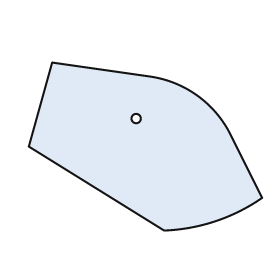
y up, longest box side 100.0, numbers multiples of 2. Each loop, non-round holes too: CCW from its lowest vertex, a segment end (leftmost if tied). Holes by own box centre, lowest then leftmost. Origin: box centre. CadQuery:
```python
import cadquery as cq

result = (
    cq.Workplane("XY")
    .moveTo(8.0, -36.0)
    .threePointArc((30.0, -32.0), (50.0, -22.0))
    .lineTo(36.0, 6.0)
    .threePointArc((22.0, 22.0), (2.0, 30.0))
    .lineTo(-40.0, 36.0)
    .lineTo(-50.0, 0.0)
    .close()
    .moveTo(-4.0, 12.0)
    .circle(2.0)
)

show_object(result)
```